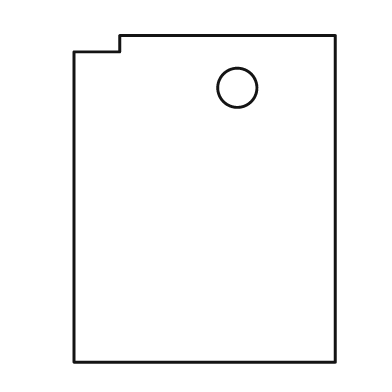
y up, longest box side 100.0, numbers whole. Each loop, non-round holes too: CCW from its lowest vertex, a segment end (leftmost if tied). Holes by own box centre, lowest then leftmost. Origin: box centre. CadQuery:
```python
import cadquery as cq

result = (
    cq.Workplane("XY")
    .moveTo(-40.0, -50.0)
    .lineTo(40.0, -50.0)
    .lineTo(40.0, 50.0)
    .lineTo(-26.0, 50.0)
    .lineTo(-26.0, 45.0)
    .lineTo(-40.0, 45.0)
    .close()
    .moveTo(10.0, 34.0)
    .circle(6.0)
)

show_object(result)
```